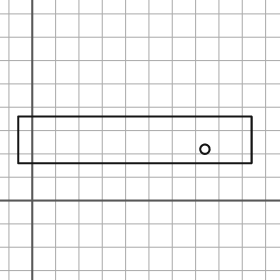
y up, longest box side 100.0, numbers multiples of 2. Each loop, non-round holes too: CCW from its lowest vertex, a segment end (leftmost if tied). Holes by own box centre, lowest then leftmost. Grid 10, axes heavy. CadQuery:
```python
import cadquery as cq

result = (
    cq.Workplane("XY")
    .moveTo(-6.0, 16.0)
    .lineTo(94.0, 16.0)
    .lineTo(94.0, 36.0)
    .lineTo(-6.0, 36.0)
    .close()
    .moveTo(74.0, 22.0)
    .circle(2.0)
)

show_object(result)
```